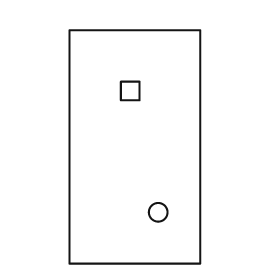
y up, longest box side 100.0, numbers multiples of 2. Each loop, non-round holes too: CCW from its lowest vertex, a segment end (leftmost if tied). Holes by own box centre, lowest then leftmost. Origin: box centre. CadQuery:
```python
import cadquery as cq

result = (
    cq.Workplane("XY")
    .moveTo(-28.0, -50.0)
    .lineTo(28.0, -50.0)
    .lineTo(28.0, 50.0)
    .lineTo(-28.0, 50.0)
    .close()
    .moveTo(10.0, -28.0)
    .circle(4.0)
    .moveTo(-6.0, 20.0)
    .lineTo(2.0, 20.0)
    .lineTo(2.0, 28.0)
    .lineTo(-6.0, 28.0)
    .close()
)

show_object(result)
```